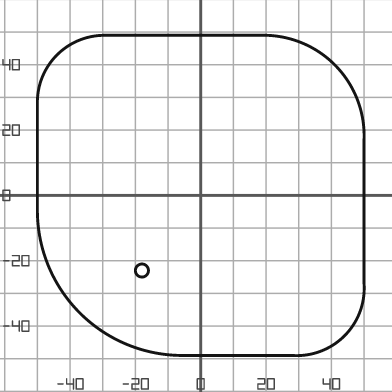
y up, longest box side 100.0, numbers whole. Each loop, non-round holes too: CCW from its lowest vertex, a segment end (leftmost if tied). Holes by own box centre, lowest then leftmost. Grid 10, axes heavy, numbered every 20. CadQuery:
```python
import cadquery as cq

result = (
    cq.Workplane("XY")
    .moveTo(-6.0, -49.0)
    .lineTo(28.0, -49.0)
    .threePointArc((44.0, -43.0), (50.0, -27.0))
    .lineTo(50.0, 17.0)
    .threePointArc((41.0, 40.0), (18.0, 49.0))
    .lineTo(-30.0, 49.0)
    .threePointArc((-44.0, 43.0), (-50.0, 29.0))
    .lineTo(-50.0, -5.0)
    .threePointArc((-37.0, -36.0), (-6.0, -49.0))
    .close()
    .moveTo(-18.0, -23.0)
    .circle(2.0)
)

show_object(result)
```